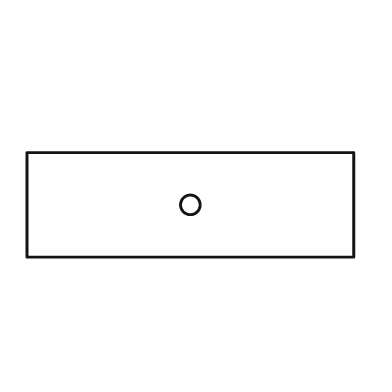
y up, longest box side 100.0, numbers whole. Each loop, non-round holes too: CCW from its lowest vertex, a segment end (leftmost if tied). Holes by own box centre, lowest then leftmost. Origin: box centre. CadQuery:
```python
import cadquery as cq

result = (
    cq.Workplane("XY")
    .moveTo(-50.0, -16.0)
    .lineTo(50.0, -16.0)
    .lineTo(50.0, 16.0)
    .lineTo(-50.0, 16.0)
    .close()
    .moveTo(0.0, 0.0)
    .circle(3.0)
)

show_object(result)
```